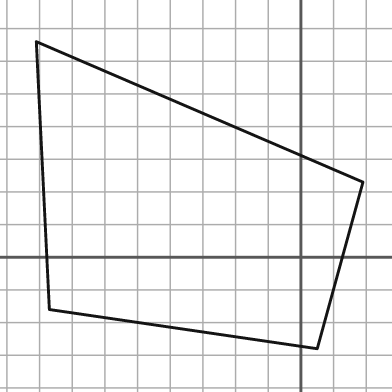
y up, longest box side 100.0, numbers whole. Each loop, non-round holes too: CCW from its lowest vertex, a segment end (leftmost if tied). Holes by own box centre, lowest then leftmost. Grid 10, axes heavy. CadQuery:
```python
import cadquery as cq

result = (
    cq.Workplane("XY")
    .moveTo(5.0, -28.0)
    .lineTo(19.0, 23.0)
    .lineTo(-81.0, 66.0)
    .lineTo(-77.0, -16.0)
    .close()
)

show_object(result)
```